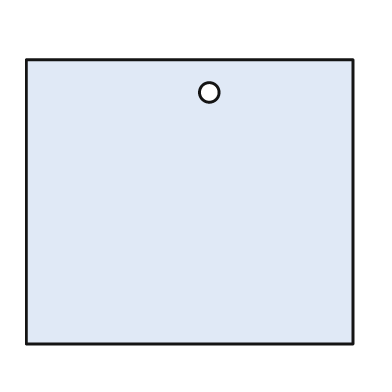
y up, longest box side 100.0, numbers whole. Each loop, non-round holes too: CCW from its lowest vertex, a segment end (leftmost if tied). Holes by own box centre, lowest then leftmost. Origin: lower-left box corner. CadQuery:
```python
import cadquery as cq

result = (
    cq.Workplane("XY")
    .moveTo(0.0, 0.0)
    .lineTo(100.0, 0.0)
    .lineTo(100.0, 87.0)
    .lineTo(0.0, 87.0)
    .close()
    .moveTo(56.0, 77.0)
    .circle(3.0)
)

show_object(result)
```